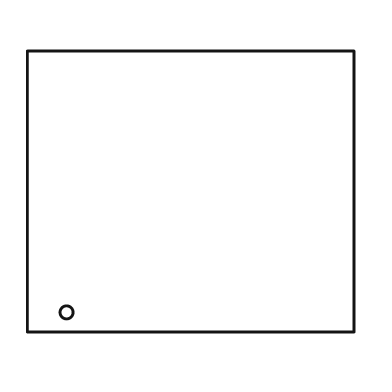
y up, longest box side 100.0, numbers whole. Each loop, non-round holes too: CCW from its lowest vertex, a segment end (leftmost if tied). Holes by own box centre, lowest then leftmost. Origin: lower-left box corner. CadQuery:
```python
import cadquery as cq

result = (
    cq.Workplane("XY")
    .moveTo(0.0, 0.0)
    .lineTo(100.0, 0.0)
    .lineTo(100.0, 86.0)
    .lineTo(0.0, 86.0)
    .close()
    .moveTo(12.0, 6.0)
    .circle(2.0)
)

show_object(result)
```